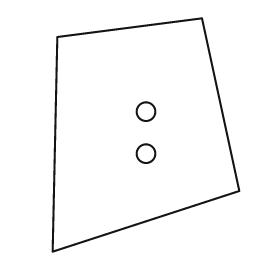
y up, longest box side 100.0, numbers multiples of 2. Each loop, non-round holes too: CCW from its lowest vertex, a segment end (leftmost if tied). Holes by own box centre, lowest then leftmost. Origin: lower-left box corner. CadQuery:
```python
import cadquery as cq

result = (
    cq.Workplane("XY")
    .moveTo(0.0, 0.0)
    .lineTo(80.0, 26.0)
    .lineTo(64.0, 100.0)
    .lineTo(2.0, 92.0)
    .close()
    .moveTo(40.0, 42.0)
    .circle(4.0)
    .moveTo(40.0, 60.0)
    .circle(4.0)
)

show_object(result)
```